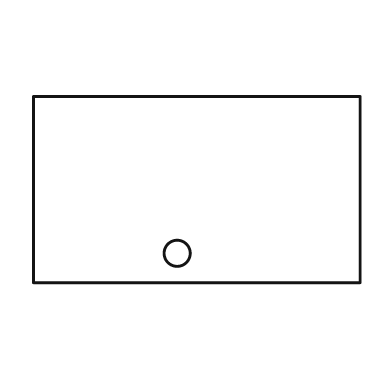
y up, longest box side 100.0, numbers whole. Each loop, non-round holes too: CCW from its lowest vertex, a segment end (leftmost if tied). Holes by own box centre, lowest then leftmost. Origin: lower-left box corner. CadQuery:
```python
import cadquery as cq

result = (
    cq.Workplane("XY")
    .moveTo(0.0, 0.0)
    .lineTo(100.0, 0.0)
    .lineTo(100.0, 57.0)
    .lineTo(0.0, 57.0)
    .close()
    .moveTo(44.0, 9.0)
    .circle(4.0)
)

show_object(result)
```